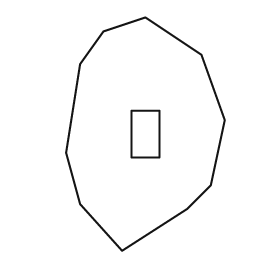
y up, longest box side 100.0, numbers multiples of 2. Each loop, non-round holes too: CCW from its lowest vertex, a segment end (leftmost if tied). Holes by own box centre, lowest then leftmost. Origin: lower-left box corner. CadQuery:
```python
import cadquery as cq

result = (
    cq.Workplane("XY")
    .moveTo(24.0, 0.0)
    .lineTo(52.0, 18.0)
    .lineTo(62.0, 28.0)
    .lineTo(68.0, 56.0)
    .lineTo(58.0, 84.0)
    .lineTo(34.0, 100.0)
    .lineTo(16.0, 94.0)
    .lineTo(6.0, 80.0)
    .lineTo(0.0, 42.0)
    .lineTo(6.0, 20.0)
    .close()
    .moveTo(28.0, 40.0)
    .lineTo(40.0, 40.0)
    .lineTo(40.0, 60.0)
    .lineTo(28.0, 60.0)
    .close()
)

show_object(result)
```